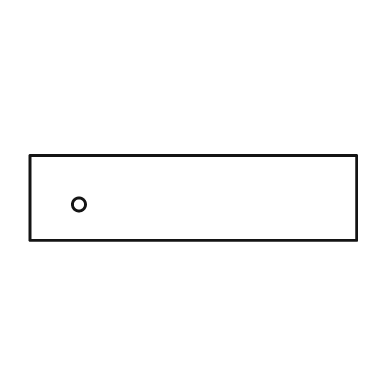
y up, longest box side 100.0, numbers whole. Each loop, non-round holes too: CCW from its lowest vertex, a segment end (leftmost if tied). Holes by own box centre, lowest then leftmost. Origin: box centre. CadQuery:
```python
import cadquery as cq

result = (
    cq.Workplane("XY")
    .moveTo(-50.0, -13.0)
    .lineTo(50.0, -13.0)
    .lineTo(50.0, 13.0)
    .lineTo(-50.0, 13.0)
    .close()
    .moveTo(-35.0, -2.0)
    .circle(2.0)
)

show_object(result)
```